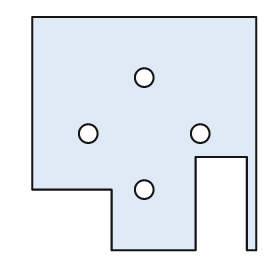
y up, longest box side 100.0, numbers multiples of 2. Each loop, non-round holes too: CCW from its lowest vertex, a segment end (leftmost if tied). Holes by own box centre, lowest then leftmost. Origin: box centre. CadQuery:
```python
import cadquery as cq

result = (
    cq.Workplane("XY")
    .moveTo(-14.0, -50.0)
    .lineTo(22.0, -50.0)
    .lineTo(22.0, -10.0)
    .lineTo(44.0, -10.0)
    .lineTo(44.0, -50.0)
    .lineTo(48.0, -50.0)
    .lineTo(48.0, 50.0)
    .lineTo(-48.0, 50.0)
    .lineTo(-48.0, -24.0)
    .lineTo(-14.0, -24.0)
    .close()
    .moveTo(0.0, -24.0)
    .circle(4.0)
    .moveTo(-24.0, 0.0)
    .circle(4.0)
    .moveTo(24.0, 0.0)
    .circle(4.0)
    .moveTo(0.0, 24.0)
    .circle(4.0)
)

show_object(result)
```